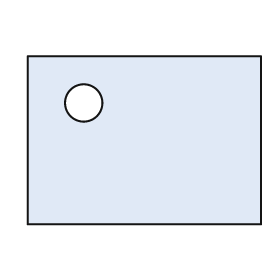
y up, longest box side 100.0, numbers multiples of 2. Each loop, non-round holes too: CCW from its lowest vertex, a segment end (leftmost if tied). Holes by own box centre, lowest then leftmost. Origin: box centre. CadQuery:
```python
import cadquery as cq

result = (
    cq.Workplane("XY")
    .moveTo(-50.0, -36.0)
    .lineTo(50.0, -36.0)
    .lineTo(50.0, 36.0)
    .lineTo(-50.0, 36.0)
    .close()
    .moveTo(-26.0, 16.0)
    .circle(8.0)
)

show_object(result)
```